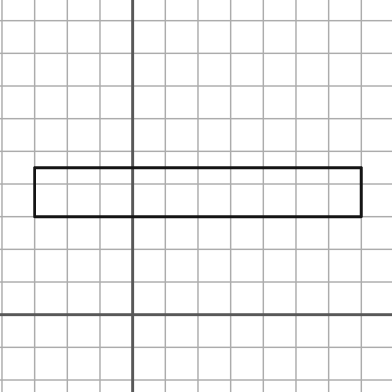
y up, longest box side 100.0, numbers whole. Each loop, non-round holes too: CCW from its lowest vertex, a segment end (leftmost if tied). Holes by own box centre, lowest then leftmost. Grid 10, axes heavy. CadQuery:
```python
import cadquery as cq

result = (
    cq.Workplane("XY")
    .moveTo(-30.0, 30.0)
    .lineTo(70.0, 30.0)
    .lineTo(70.0, 45.0)
    .lineTo(-30.0, 45.0)
    .close()
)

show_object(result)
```